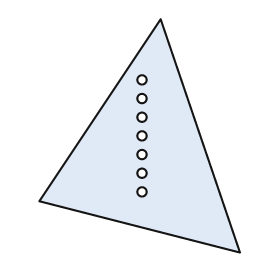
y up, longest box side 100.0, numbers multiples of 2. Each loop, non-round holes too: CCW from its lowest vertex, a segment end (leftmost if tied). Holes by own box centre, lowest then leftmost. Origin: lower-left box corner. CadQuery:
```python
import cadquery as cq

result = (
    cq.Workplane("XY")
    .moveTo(86.0, 0.0)
    .lineTo(52.0, 100.0)
    .lineTo(0.0, 22.0)
    .close()
    .moveTo(44.0, 26.0)
    .circle(2.0)
    .moveTo(44.0, 34.0)
    .circle(2.0)
    .moveTo(44.0, 42.0)
    .circle(2.0)
    .moveTo(44.0, 50.0)
    .circle(2.0)
    .moveTo(44.0, 58.0)
    .circle(2.0)
    .moveTo(44.0, 66.0)
    .circle(2.0)
    .moveTo(44.0, 74.0)
    .circle(2.0)
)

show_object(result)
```